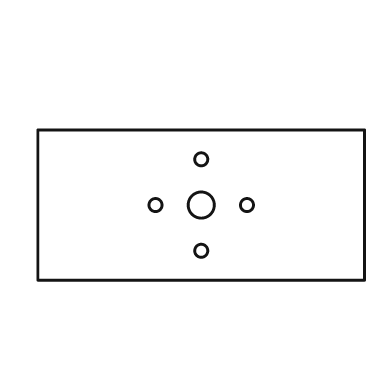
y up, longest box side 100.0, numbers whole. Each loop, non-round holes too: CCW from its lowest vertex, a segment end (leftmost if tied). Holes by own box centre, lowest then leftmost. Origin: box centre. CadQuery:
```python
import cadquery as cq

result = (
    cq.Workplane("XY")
    .moveTo(-50.0, -23.0)
    .lineTo(50.0, -23.0)
    .lineTo(50.0, 23.0)
    .lineTo(-50.0, 23.0)
    .close()
    .moveTo(0.0, -14.0)
    .circle(2.0)
    .moveTo(-14.0, 0.0)
    .circle(2.0)
    .moveTo(0.0, 0.0)
    .circle(4.0)
    .moveTo(14.0, 0.0)
    .circle(2.0)
    .moveTo(0.0, 14.0)
    .circle(2.0)
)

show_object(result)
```